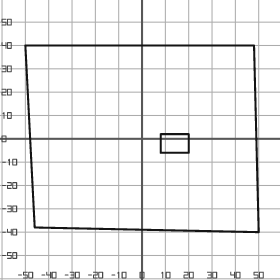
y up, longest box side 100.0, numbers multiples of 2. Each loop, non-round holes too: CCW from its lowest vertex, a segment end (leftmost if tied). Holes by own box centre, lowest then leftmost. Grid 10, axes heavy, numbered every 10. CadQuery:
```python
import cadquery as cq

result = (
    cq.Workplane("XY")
    .moveTo(50.0, -40.0)
    .lineTo(48.0, 40.0)
    .lineTo(-50.0, 40.0)
    .lineTo(-46.0, -38.0)
    .close()
    .moveTo(8.0, -6.0)
    .lineTo(20.0, -6.0)
    .lineTo(20.0, 2.0)
    .lineTo(8.0, 2.0)
    .close()
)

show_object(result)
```